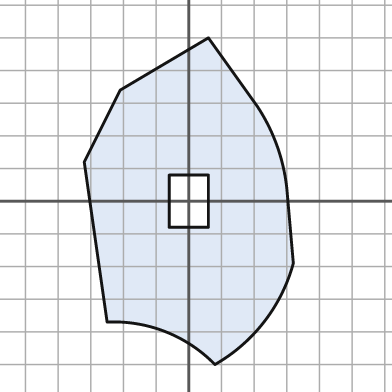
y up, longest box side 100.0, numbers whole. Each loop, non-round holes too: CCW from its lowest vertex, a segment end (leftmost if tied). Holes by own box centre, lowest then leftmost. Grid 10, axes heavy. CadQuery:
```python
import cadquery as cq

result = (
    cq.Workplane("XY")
    .moveTo(8.0, -50.0)
    .threePointArc((23.0, -37.0), (32.0, -19.0))
    .lineTo(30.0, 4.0)
    .threePointArc((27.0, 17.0), (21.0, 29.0))
    .lineTo(6.0, 50.0)
    .lineTo(-21.0, 34.0)
    .lineTo(-32.0, 12.0)
    .lineTo(-25.0, -37.0)
    .threePointArc((-7.0, -40.0), (8.0, -50.0))
    .close()
    .moveTo(-6.0, -8.0)
    .lineTo(6.0, -8.0)
    .lineTo(6.0, 8.0)
    .lineTo(-6.0, 8.0)
    .close()
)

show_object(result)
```